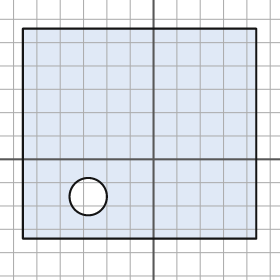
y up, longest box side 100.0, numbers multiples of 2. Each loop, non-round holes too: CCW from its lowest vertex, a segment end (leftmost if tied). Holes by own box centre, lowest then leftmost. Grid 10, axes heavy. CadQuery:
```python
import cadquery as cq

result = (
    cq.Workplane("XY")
    .moveTo(-56.0, -34.0)
    .lineTo(44.0, -34.0)
    .lineTo(44.0, 56.0)
    .lineTo(-56.0, 56.0)
    .close()
    .moveTo(-28.0, -16.0)
    .circle(8.0)
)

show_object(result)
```